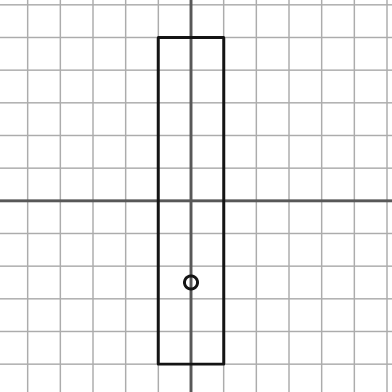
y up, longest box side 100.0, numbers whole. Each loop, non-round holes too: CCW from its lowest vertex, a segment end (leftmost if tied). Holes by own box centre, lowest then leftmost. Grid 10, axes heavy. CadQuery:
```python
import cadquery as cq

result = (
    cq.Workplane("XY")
    .moveTo(-10.0, -50.0)
    .lineTo(10.0, -50.0)
    .lineTo(10.0, 50.0)
    .lineTo(-10.0, 50.0)
    .close()
    .moveTo(0.0, -25.0)
    .circle(2.0)
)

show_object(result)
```